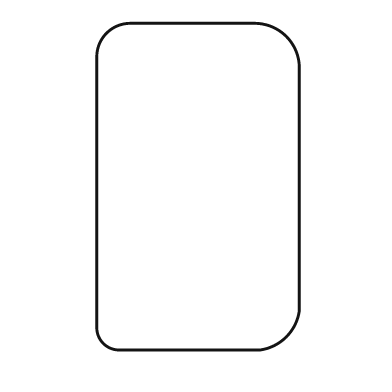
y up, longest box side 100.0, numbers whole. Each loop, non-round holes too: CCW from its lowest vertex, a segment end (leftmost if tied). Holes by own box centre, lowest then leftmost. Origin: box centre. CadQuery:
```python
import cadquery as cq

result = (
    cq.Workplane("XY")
    .moveTo(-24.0, -50.0)
    .lineTo(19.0, -50.0)
    .threePointArc((27.0, -46.0), (31.0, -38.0))
    .lineTo(31.0, 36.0)
    .threePointArc((27.0, 46.0), (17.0, 50.0))
    .lineTo(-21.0, 50.0)
    .threePointArc((-28.0, 47.0), (-31.0, 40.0))
    .lineTo(-31.0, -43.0)
    .threePointArc((-29.0, -48.0), (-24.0, -50.0))
    .close()
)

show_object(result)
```